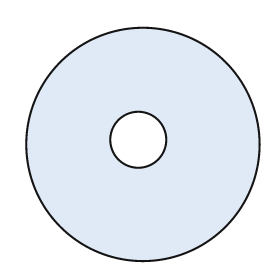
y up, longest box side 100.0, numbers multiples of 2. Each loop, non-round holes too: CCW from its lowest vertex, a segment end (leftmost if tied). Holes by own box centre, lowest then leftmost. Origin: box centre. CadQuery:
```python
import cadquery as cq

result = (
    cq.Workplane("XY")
    .moveTo(0.0, 0.0)
    .circle(50.0)
    .moveTo(-2.0, 2.0)
    .circle(12.0)
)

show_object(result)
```